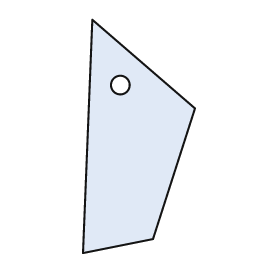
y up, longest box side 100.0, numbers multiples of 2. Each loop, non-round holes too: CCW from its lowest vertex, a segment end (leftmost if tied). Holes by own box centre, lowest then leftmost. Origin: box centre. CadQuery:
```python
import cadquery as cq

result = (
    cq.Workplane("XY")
    .moveTo(-24.0, -50.0)
    .lineTo(6.0, -44.0)
    .lineTo(24.0, 12.0)
    .lineTo(-20.0, 50.0)
    .close()
    .moveTo(-8.0, 22.0)
    .circle(4.0)
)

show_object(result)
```